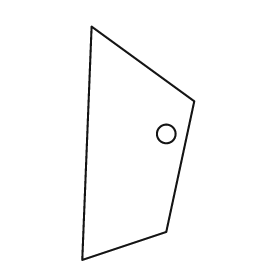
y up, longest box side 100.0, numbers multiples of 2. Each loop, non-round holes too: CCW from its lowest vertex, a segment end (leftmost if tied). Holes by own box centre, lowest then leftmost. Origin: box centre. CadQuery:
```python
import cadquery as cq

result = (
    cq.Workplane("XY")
    .moveTo(-24.0, -50.0)
    .lineTo(12.0, -38.0)
    .lineTo(24.0, 18.0)
    .lineTo(-20.0, 50.0)
    .close()
    .moveTo(12.0, 4.0)
    .circle(4.0)
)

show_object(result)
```